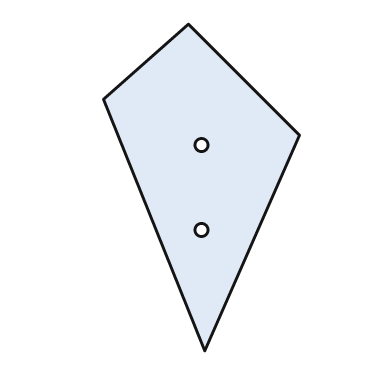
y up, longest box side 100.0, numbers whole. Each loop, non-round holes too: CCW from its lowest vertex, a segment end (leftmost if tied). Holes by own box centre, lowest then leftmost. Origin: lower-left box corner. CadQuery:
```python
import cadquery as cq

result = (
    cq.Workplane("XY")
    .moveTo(31.0, 0.0)
    .lineTo(60.0, 66.0)
    .lineTo(26.0, 100.0)
    .lineTo(0.0, 77.0)
    .close()
    .moveTo(30.0, 37.0)
    .circle(2.0)
    .moveTo(30.0, 63.0)
    .circle(2.0)
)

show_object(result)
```